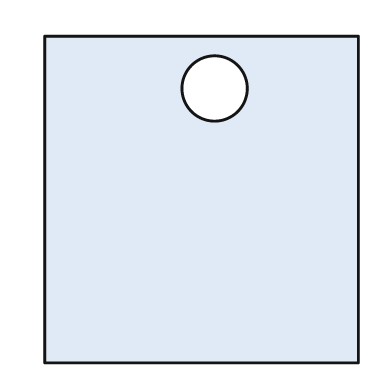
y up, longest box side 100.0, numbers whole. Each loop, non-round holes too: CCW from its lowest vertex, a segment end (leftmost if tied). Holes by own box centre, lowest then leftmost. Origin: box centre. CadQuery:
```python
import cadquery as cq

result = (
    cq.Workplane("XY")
    .moveTo(-48.0, -50.0)
    .lineTo(48.0, -50.0)
    .lineTo(48.0, 50.0)
    .lineTo(-48.0, 50.0)
    .close()
    .moveTo(4.0, 34.0)
    .circle(10.0)
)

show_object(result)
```